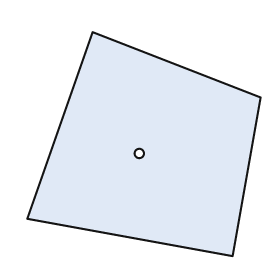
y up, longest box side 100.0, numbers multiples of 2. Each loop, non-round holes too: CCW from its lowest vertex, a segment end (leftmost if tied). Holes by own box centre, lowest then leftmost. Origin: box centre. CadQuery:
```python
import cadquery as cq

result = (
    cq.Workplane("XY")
    .moveTo(38.0, -48.0)
    .lineTo(50.0, 20.0)
    .lineTo(-22.0, 48.0)
    .lineTo(-50.0, -32.0)
    .close()
    .moveTo(-2.0, -4.0)
    .circle(2.0)
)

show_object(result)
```